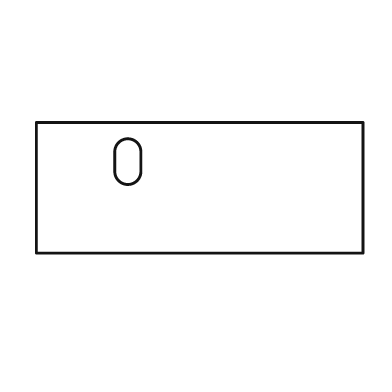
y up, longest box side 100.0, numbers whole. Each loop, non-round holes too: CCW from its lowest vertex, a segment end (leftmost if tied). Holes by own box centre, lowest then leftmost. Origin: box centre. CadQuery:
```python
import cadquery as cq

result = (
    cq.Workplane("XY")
    .moveTo(-50.0, -20.0)
    .lineTo(50.0, -20.0)
    .lineTo(50.0, 20.0)
    .lineTo(-50.0, 20.0)
    .close()
    .moveTo(-26.0, 5.0)
    .threePointArc((-22.0, 1.0), (-18.0, 5.0))
    .lineTo(-18.0, 11.0)
    .threePointArc((-22.0, 15.0), (-26.0, 11.0))
    .close()
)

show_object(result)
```